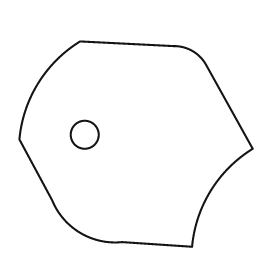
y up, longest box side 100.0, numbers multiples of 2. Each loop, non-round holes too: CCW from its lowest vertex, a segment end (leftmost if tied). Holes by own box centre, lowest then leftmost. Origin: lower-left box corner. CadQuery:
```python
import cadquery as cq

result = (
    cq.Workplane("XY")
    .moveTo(74.0, 0.0)
    .threePointArc((82.0, 24.0), (100.0, 42.0))
    .lineTo(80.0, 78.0)
    .threePointArc((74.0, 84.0), (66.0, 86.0))
    .lineTo(26.0, 88.0)
    .threePointArc((8.0, 70.0), (0.0, 46.0))
    .lineTo(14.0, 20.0)
    .threePointArc((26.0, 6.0), (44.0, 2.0))
    .close()
    .moveTo(28.0, 48.0)
    .circle(6.0)
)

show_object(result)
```